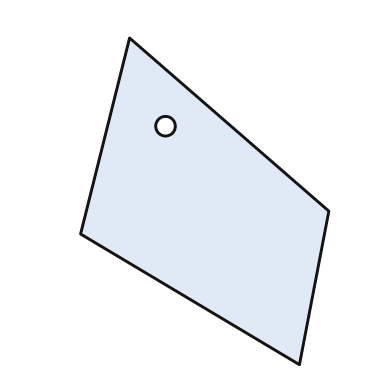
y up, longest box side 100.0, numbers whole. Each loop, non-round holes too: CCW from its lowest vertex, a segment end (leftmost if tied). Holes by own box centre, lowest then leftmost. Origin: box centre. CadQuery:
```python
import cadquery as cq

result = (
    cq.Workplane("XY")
    .moveTo(29.0, -50.0)
    .lineTo(38.0, -3.0)
    .lineTo(-23.0, 50.0)
    .lineTo(-38.0, -10.0)
    .close()
    .moveTo(-12.0, 23.0)
    .circle(3.0)
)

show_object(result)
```